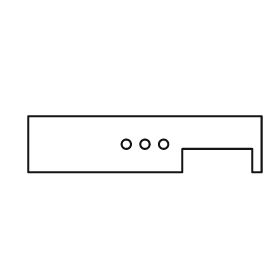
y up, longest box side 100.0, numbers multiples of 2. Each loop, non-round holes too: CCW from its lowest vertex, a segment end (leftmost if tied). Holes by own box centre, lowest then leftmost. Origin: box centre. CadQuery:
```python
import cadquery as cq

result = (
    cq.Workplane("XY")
    .moveTo(-50.0, -12.0)
    .lineTo(16.0, -12.0)
    .lineTo(16.0, -2.0)
    .lineTo(46.0, -2.0)
    .lineTo(46.0, -12.0)
    .lineTo(50.0, -12.0)
    .lineTo(50.0, 12.0)
    .lineTo(-50.0, 12.0)
    .close()
    .moveTo(-8.0, 0.0)
    .circle(2.0)
    .moveTo(0.0, 0.0)
    .circle(2.0)
    .moveTo(8.0, 0.0)
    .circle(2.0)
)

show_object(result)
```